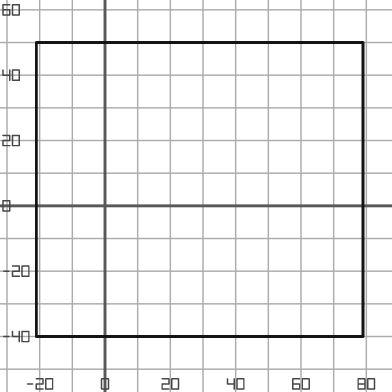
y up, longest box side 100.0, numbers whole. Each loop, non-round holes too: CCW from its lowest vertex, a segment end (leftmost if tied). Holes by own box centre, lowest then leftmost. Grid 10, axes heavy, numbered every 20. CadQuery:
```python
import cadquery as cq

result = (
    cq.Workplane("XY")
    .moveTo(-21.0, -40.0)
    .lineTo(79.0, -40.0)
    .lineTo(79.0, 50.0)
    .lineTo(-21.0, 50.0)
    .close()
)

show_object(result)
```